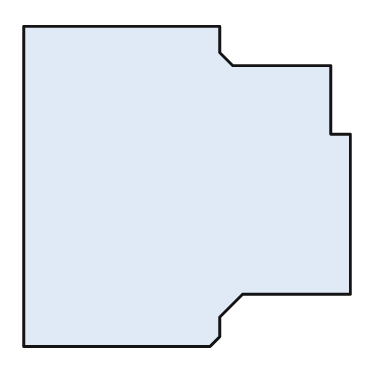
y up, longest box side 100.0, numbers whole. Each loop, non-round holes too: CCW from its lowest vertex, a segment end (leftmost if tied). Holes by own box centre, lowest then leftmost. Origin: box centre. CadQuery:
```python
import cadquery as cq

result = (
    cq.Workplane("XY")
    .moveTo(-50.0, -49.0)
    .lineTo(7.0, -49.0)
    .lineTo(10.0, -46.0)
    .lineTo(10.0, -40.0)
    .lineTo(17.0, -33.0)
    .lineTo(50.0, -33.0)
    .lineTo(50.0, 16.0)
    .lineTo(44.0, 16.0)
    .lineTo(44.0, 37.0)
    .lineTo(14.0, 37.0)
    .lineTo(10.0, 41.0)
    .lineTo(10.0, 49.0)
    .lineTo(-50.0, 49.0)
    .close()
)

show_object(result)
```